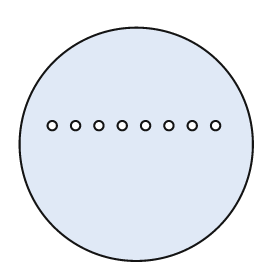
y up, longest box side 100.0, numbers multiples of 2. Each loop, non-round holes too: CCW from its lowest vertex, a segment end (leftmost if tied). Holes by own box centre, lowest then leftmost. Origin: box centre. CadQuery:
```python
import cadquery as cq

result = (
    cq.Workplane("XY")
    .moveTo(0.0, 0.0)
    .circle(50.0)
    .moveTo(-36.0, 8.0)
    .circle(2.0)
    .moveTo(-26.0, 8.0)
    .circle(2.0)
    .moveTo(-16.0, 8.0)
    .circle(2.0)
    .moveTo(-6.0, 8.0)
    .circle(2.0)
    .moveTo(4.0, 8.0)
    .circle(2.0)
    .moveTo(14.0, 8.0)
    .circle(2.0)
    .moveTo(24.0, 8.0)
    .circle(2.0)
    .moveTo(34.0, 8.0)
    .circle(2.0)
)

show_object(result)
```